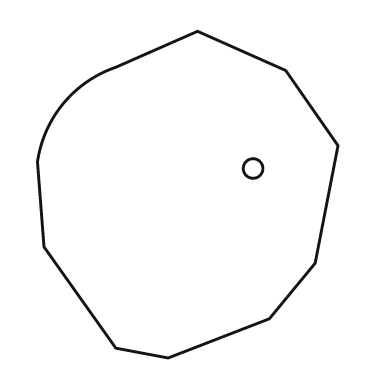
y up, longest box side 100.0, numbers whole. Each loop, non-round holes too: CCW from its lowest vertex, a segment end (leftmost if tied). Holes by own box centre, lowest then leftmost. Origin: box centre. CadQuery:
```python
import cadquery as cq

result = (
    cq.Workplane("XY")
    .moveTo(-6.0, -50.0)
    .lineTo(25.0, -38.0)
    .lineTo(39.0, -21.0)
    .lineTo(46.0, 15.0)
    .lineTo(30.0, 38.0)
    .lineTo(3.0, 50.0)
    .lineTo(-22.0, 39.0)
    .threePointArc((-38.0, 28.0), (-46.0, 10.0))
    .lineTo(-44.0, -16.0)
    .lineTo(-22.0, -47.0)
    .close()
    .moveTo(20.0, 8.0)
    .circle(3.0)
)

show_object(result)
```